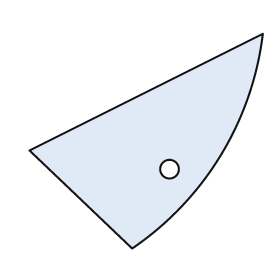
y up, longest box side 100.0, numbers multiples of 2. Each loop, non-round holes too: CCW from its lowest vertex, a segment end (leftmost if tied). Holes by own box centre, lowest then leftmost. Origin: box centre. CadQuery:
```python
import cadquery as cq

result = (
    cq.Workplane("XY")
    .moveTo(-6.0, -46.0)
    .threePointArc((32.0, -6.0), (50.0, 46.0))
    .lineTo(-50.0, -4.0)
    .close()
    .moveTo(10.0, -12.0)
    .circle(4.0)
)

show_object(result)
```